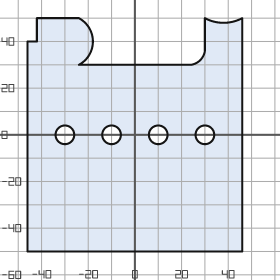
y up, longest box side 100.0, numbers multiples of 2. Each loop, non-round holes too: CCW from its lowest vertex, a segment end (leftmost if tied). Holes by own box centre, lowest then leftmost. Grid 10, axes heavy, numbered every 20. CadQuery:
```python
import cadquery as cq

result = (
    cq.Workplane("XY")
    .moveTo(-46.0, -50.0)
    .lineTo(46.0, -50.0)
    .lineTo(46.0, 50.0)
    .threePointArc((38.0, 48.0), (30.0, 50.0))
    .lineTo(30.0, 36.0)
    .threePointArc((28.0, 32.0), (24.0, 30.0))
    .lineTo(-24.0, 30.0)
    .threePointArc((-18.0, 40.0), (-24.0, 50.0))
    .lineTo(-42.0, 50.0)
    .lineTo(-42.0, 40.0)
    .lineTo(-46.0, 40.0)
    .close()
    .moveTo(-30.0, 0.0)
    .circle(4.0)
    .moveTo(-10.0, 0.0)
    .circle(4.0)
    .moveTo(10.0, 0.0)
    .circle(4.0)
    .moveTo(30.0, 0.0)
    .circle(4.0)
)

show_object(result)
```